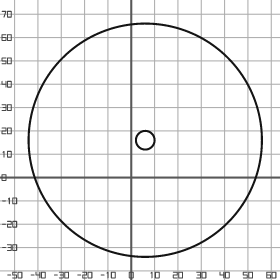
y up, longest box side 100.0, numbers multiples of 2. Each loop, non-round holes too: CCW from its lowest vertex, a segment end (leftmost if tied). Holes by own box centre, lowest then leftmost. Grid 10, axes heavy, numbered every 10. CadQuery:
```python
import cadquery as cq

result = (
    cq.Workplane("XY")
    .moveTo(6.0, 16.0)
    .circle(50.0)
    .moveTo(6.0, 16.0)
    .circle(4.0)
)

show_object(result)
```